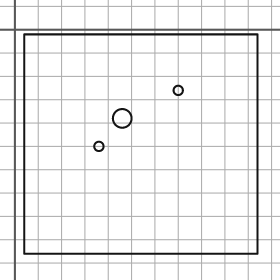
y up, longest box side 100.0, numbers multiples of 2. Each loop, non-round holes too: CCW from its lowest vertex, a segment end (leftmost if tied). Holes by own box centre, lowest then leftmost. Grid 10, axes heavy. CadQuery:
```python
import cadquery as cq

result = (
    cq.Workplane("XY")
    .moveTo(4.0, -96.0)
    .lineTo(104.0, -96.0)
    .lineTo(104.0, -2.0)
    .lineTo(4.0, -2.0)
    .close()
    .moveTo(36.0, -50.0)
    .circle(2.0)
    .moveTo(46.0, -38.0)
    .circle(4.0)
    .moveTo(70.0, -26.0)
    .circle(2.0)
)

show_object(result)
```